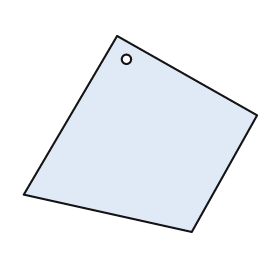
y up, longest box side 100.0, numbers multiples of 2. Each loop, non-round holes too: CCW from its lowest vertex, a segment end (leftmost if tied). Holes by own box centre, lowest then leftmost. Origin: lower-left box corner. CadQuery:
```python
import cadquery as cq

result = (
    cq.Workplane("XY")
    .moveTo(72.0, 0.0)
    .lineTo(100.0, 50.0)
    .lineTo(40.0, 84.0)
    .lineTo(0.0, 16.0)
    .close()
    .moveTo(44.0, 74.0)
    .circle(2.0)
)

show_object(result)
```